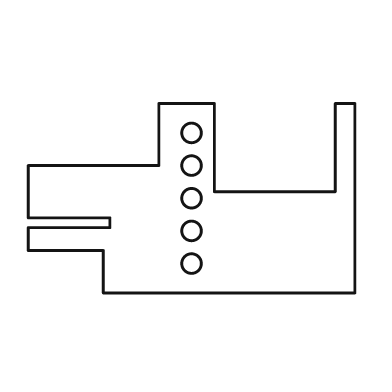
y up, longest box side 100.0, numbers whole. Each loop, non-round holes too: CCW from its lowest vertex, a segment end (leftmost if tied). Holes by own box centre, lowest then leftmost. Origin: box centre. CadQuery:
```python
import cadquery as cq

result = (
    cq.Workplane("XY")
    .moveTo(-27.0, -29.0)
    .lineTo(50.0, -29.0)
    .lineTo(50.0, 29.0)
    .lineTo(44.0, 29.0)
    .lineTo(44.0, 2.0)
    .lineTo(7.0, 2.0)
    .lineTo(7.0, 29.0)
    .lineTo(-10.0, 29.0)
    .lineTo(-10.0, 10.0)
    .lineTo(-50.0, 10.0)
    .lineTo(-50.0, -6.0)
    .lineTo(-25.0, -6.0)
    .lineTo(-25.0, -9.0)
    .lineTo(-50.0, -9.0)
    .lineTo(-50.0, -16.0)
    .lineTo(-27.0, -16.0)
    .close()
    .moveTo(0.0, -20.0)
    .circle(3.0)
    .moveTo(0.0, -10.0)
    .circle(3.0)
    .moveTo(0.0, 0.0)
    .circle(3.0)
    .moveTo(0.0, 10.0)
    .circle(3.0)
    .moveTo(0.0, 20.0)
    .circle(3.0)
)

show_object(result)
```